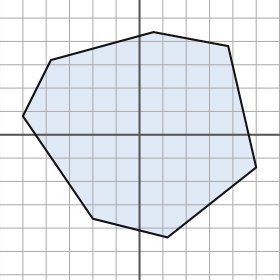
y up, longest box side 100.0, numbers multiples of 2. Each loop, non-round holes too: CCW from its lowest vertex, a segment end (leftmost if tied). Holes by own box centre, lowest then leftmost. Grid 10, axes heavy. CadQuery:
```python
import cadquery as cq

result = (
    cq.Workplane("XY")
    .moveTo(12.0, -44.0)
    .lineTo(50.0, -14.0)
    .lineTo(38.0, 38.0)
    .lineTo(6.0, 44.0)
    .lineTo(-38.0, 32.0)
    .lineTo(-50.0, 8.0)
    .lineTo(-20.0, -36.0)
    .close()
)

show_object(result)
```